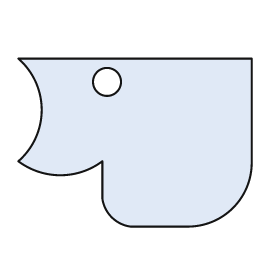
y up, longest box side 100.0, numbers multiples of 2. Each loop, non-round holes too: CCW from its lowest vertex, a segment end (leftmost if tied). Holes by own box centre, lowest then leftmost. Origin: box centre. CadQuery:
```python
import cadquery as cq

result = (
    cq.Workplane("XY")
    .moveTo(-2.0, -36.0)
    .lineTo(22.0, -36.0)
    .threePointArc((42.0, -28.0), (50.0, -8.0))
    .lineTo(50.0, 36.0)
    .lineTo(-50.0, 36.0)
    .threePointArc((-40.0, 14.0), (-50.0, -8.0))
    .threePointArc((-32.0, -14.0), (-14.0, -8.0))
    .lineTo(-14.0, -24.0)
    .threePointArc((-10.0, -32.0), (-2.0, -36.0))
    .close()
    .moveTo(-12.0, 26.0)
    .circle(6.0)
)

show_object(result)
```